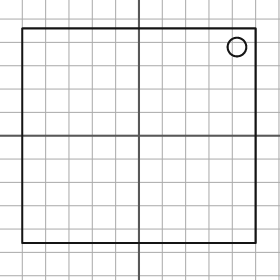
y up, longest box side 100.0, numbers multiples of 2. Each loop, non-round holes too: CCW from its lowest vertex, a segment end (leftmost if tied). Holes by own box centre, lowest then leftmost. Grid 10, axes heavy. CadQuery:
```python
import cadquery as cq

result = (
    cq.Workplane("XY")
    .moveTo(-50.0, -46.0)
    .lineTo(50.0, -46.0)
    .lineTo(50.0, 46.0)
    .lineTo(-50.0, 46.0)
    .close()
    .moveTo(42.0, 38.0)
    .circle(4.0)
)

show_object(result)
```